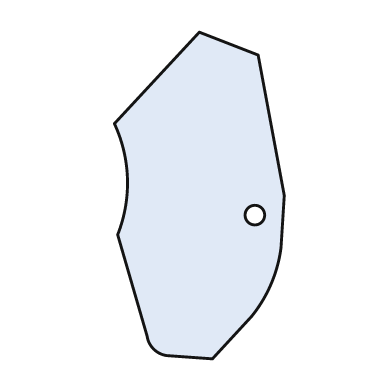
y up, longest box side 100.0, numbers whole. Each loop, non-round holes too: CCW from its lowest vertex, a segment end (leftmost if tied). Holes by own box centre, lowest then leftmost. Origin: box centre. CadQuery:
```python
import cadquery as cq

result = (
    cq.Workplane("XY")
    .moveTo(4.0, -50.0)
    .lineTo(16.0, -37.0)
    .threePointArc((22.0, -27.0), (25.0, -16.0))
    .lineTo(26.0, 0.0)
    .lineTo(18.0, 43.0)
    .lineTo(0.0, 50.0)
    .lineTo(-26.0, 22.0)
    .threePointArc((-22.0, 5.0), (-25.0, -12.0))
    .lineTo(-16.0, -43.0)
    .threePointArc((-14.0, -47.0), (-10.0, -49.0))
    .close()
    .moveTo(17.0, -6.0)
    .circle(3.0)
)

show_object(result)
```